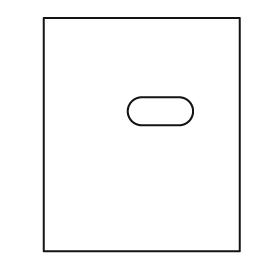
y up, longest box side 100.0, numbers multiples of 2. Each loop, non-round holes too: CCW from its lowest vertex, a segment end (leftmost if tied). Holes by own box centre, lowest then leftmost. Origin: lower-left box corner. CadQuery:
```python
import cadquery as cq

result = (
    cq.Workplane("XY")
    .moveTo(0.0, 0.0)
    .lineTo(84.0, 0.0)
    .lineTo(84.0, 100.0)
    .lineTo(0.0, 100.0)
    .close()
    .moveTo(42.0, 54.0)
    .lineTo(58.0, 54.0)
    .threePointArc((64.0, 60.0), (58.0, 66.0))
    .lineTo(42.0, 66.0)
    .threePointArc((36.0, 60.0), (42.0, 54.0))
    .close()
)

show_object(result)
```